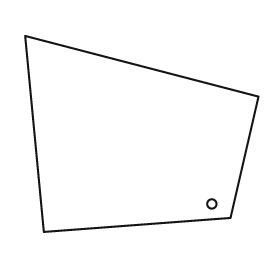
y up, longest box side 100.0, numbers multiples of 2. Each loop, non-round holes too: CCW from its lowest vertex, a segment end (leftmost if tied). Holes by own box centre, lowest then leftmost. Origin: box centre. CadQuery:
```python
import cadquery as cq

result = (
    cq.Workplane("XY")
    .moveTo(-42.0, -42.0)
    .lineTo(38.0, -36.0)
    .lineTo(50.0, 16.0)
    .lineTo(-50.0, 42.0)
    .close()
    .moveTo(30.0, -30.0)
    .circle(2.0)
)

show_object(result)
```